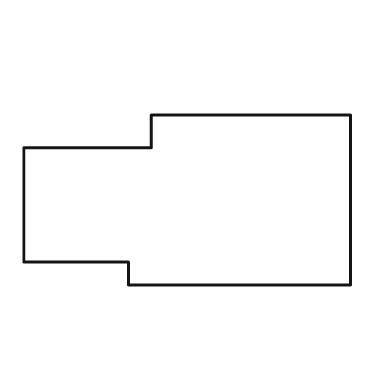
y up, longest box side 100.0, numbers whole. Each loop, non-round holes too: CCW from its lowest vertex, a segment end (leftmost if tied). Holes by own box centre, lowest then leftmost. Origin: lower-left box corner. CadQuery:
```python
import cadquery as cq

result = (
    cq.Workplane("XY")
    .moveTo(32.0, 0.0)
    .lineTo(100.0, 0.0)
    .lineTo(100.0, 52.0)
    .lineTo(39.0, 52.0)
    .lineTo(39.0, 42.0)
    .lineTo(0.0, 42.0)
    .lineTo(0.0, 7.0)
    .lineTo(32.0, 7.0)
    .close()
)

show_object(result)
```